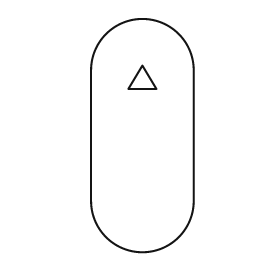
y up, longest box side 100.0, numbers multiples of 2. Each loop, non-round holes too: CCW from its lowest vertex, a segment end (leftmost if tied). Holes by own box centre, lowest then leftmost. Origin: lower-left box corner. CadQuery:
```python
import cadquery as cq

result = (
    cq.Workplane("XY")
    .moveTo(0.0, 22.0)
    .threePointArc((22.0, 0.0), (44.0, 22.0))
    .lineTo(44.0, 78.0)
    .threePointArc((22.0, 100.0), (0.0, 78.0))
    .close()
    .moveTo(16.0, 70.0)
    .lineTo(28.0, 70.0)
    .lineTo(22.0, 80.0)
    .close()
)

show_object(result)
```